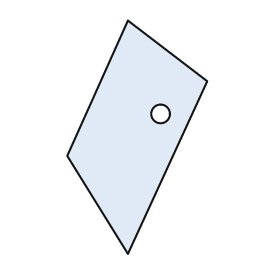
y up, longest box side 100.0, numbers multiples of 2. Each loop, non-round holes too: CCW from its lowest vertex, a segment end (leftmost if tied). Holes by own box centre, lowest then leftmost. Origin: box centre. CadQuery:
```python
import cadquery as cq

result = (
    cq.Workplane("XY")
    .moveTo(-4.0, -50.0)
    .lineTo(30.0, 24.0)
    .lineTo(-4.0, 50.0)
    .lineTo(-30.0, -8.0)
    .close()
    .moveTo(10.0, 10.0)
    .circle(4.0)
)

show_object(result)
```